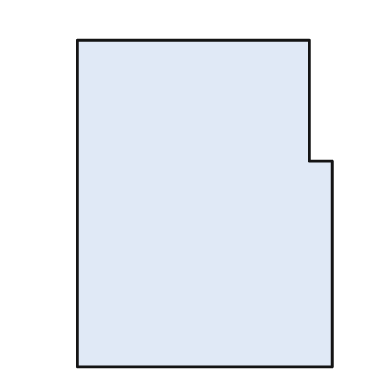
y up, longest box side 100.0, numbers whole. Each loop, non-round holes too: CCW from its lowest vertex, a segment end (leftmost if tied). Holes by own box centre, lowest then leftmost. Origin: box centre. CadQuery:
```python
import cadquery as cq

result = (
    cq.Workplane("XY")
    .moveTo(-39.0, -50.0)
    .lineTo(39.0, -50.0)
    .lineTo(39.0, 13.0)
    .lineTo(32.0, 13.0)
    .lineTo(32.0, 50.0)
    .lineTo(-39.0, 50.0)
    .close()
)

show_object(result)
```